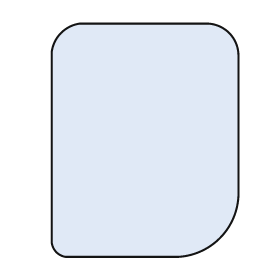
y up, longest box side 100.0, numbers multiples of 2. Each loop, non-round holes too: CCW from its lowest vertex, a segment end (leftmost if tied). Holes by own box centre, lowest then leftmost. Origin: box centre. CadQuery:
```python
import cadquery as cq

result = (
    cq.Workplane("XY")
    .moveTo(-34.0, -50.0)
    .lineTo(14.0, -50.0)
    .threePointArc((32.0, -42.0), (40.0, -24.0))
    .lineTo(40.0, 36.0)
    .threePointArc((36.0, 46.0), (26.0, 50.0))
    .lineTo(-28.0, 50.0)
    .threePointArc((-36.0, 46.0), (-40.0, 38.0))
    .lineTo(-40.0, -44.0)
    .threePointArc((-38.0, -48.0), (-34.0, -50.0))
    .close()
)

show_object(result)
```